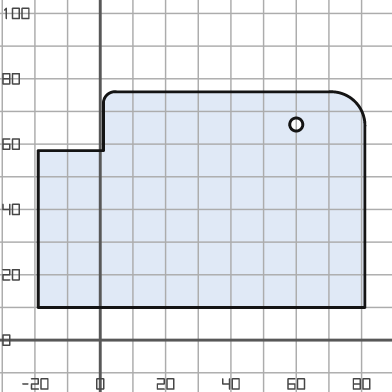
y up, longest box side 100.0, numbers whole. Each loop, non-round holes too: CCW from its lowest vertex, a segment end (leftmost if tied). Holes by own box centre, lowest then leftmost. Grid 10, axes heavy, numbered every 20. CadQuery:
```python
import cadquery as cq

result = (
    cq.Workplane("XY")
    .moveTo(-19.0, 10.0)
    .lineTo(81.0, 10.0)
    .lineTo(81.0, 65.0)
    .threePointArc((78.0, 73.0), (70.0, 76.0))
    .lineTo(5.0, 76.0)
    .threePointArc((2.0, 75.0), (1.0, 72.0))
    .lineTo(1.0, 58.0)
    .lineTo(-19.0, 58.0)
    .close()
    .moveTo(60.0, 66.0)
    .circle(2.0)
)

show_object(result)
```